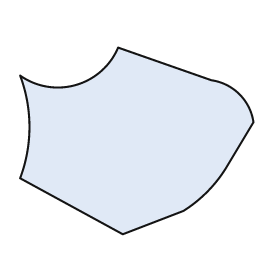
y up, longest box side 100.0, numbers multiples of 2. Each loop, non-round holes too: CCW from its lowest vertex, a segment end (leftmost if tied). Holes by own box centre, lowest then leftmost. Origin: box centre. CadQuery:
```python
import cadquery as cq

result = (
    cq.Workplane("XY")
    .moveTo(-6.0, -40.0)
    .lineTo(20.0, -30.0)
    .threePointArc((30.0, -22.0), (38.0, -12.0))
    .lineTo(50.0, 8.0)
    .threePointArc((44.0, 20.0), (32.0, 26.0))
    .lineTo(-8.0, 40.0)
    .threePointArc((-26.0, 24.0), (-50.0, 28.0))
    .threePointArc((-46.0, 6.0), (-50.0, -16.0))
    .close()
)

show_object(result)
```